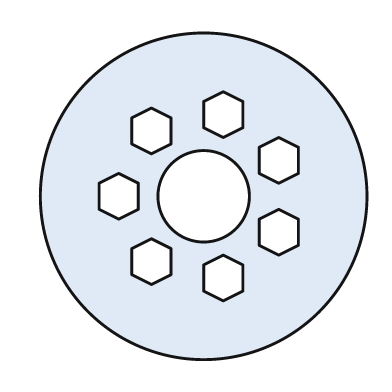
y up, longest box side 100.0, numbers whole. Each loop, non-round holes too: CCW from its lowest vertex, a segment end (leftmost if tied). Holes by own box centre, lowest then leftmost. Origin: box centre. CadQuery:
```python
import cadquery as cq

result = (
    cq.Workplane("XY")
    .moveTo(0.0, 0.0)
    .circle(50.0)
    .moveTo(6.0, -32.0)
    .lineTo(12.0, -29.0)
    .lineTo(12.0, -21.0)
    .lineTo(6.0, -18.0)
    .lineTo(0.0, -21.0)
    .lineTo(0.0, -29.0)
    .close()
    .moveTo(-16.0, -27.0)
    .lineTo(-10.0, -24.0)
    .lineTo(-10.0, -16.0)
    .lineTo(-16.0, -13.0)
    .lineTo(-22.0, -16.0)
    .lineTo(-22.0, -24.0)
    .close()
    .moveTo(23.0, -18.0)
    .lineTo(29.0, -15.0)
    .lineTo(29.0, -7.0)
    .lineTo(23.0, -4.0)
    .lineTo(17.0, -7.0)
    .lineTo(17.0, -15.0)
    .close()
    .moveTo(-26.0, -7.0)
    .lineTo(-20.0, -4.0)
    .lineTo(-20.0, 4.0)
    .lineTo(-26.0, 7.0)
    .lineTo(-32.0, 4.0)
    .lineTo(-32.0, -4.0)
    .close()
    .moveTo(0.0, 0.0)
    .circle(14.0)
    .moveTo(23.0, 4.0)
    .lineTo(29.0, 7.0)
    .lineTo(29.0, 15.0)
    .lineTo(23.0, 18.0)
    .lineTo(17.0, 15.0)
    .lineTo(17.0, 7.0)
    .close()
    .moveTo(-16.0, 13.0)
    .lineTo(-10.0, 16.0)
    .lineTo(-10.0, 24.0)
    .lineTo(-16.0, 27.0)
    .lineTo(-22.0, 24.0)
    .lineTo(-22.0, 16.0)
    .close()
    .moveTo(6.0, 18.0)
    .lineTo(12.0, 21.0)
    .lineTo(12.0, 29.0)
    .lineTo(6.0, 32.0)
    .lineTo(0.0, 29.0)
    .lineTo(0.0, 21.0)
    .close()
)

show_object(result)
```